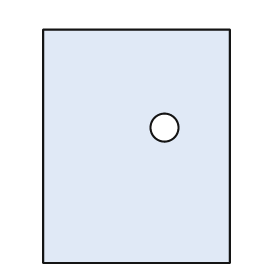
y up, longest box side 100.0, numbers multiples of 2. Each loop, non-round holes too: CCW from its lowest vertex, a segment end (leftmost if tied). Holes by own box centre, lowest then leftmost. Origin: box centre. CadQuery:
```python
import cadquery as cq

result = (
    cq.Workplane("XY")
    .moveTo(-40.0, -50.0)
    .lineTo(40.0, -50.0)
    .lineTo(40.0, 50.0)
    .lineTo(-40.0, 50.0)
    .close()
    .moveTo(12.0, 8.0)
    .circle(6.0)
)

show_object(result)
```